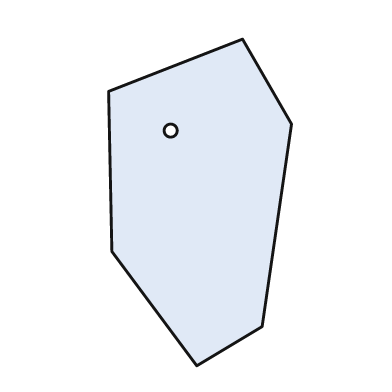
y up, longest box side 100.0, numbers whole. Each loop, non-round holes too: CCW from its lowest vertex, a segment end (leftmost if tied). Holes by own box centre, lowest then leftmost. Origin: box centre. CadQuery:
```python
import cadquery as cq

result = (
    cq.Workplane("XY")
    .moveTo(-1.0, -50.0)
    .lineTo(19.0, -38.0)
    .lineTo(28.0, 24.0)
    .lineTo(13.0, 50.0)
    .lineTo(-28.0, 34.0)
    .lineTo(-27.0, -15.0)
    .close()
    .moveTo(-9.0, 22.0)
    .circle(2.0)
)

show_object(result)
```